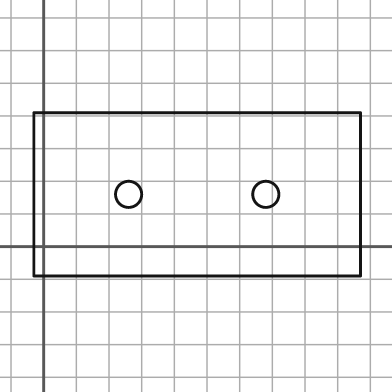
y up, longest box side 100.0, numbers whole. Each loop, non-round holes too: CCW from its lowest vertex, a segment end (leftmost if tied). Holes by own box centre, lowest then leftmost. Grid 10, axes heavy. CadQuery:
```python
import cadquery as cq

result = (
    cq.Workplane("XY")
    .moveTo(-3.0, -9.0)
    .lineTo(97.0, -9.0)
    .lineTo(97.0, 41.0)
    .lineTo(-3.0, 41.0)
    .close()
    .moveTo(26.0, 16.0)
    .circle(4.0)
    .moveTo(68.0, 16.0)
    .circle(4.0)
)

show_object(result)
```